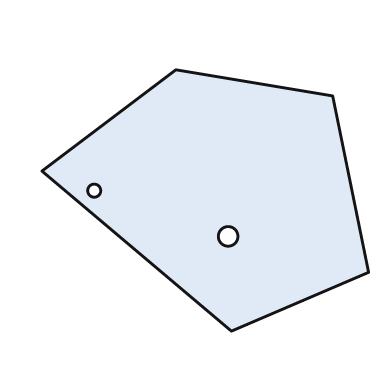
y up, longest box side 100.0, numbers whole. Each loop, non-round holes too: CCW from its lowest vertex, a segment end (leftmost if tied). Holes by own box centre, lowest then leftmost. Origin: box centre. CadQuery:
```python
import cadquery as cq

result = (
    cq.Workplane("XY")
    .moveTo(8.0, -40.0)
    .lineTo(50.0, -22.0)
    .lineTo(39.0, 32.0)
    .lineTo(-9.0, 40.0)
    .lineTo(-50.0, 9.0)
    .close()
    .moveTo(7.0, -11.0)
    .circle(3.0)
    .moveTo(-34.0, 3.0)
    .circle(2.0)
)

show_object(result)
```